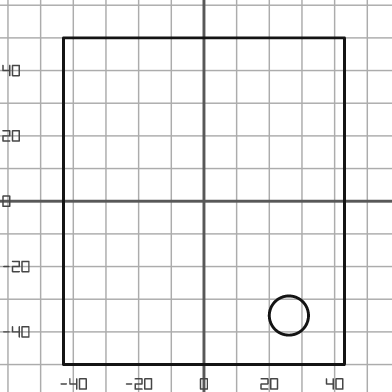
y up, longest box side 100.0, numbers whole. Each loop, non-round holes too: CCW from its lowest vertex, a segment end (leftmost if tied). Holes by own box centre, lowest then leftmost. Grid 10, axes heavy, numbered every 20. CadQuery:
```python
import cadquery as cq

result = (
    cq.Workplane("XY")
    .moveTo(-43.0, -50.0)
    .lineTo(43.0, -50.0)
    .lineTo(43.0, 50.0)
    .lineTo(-43.0, 50.0)
    .close()
    .moveTo(26.0, -35.0)
    .circle(6.0)
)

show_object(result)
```